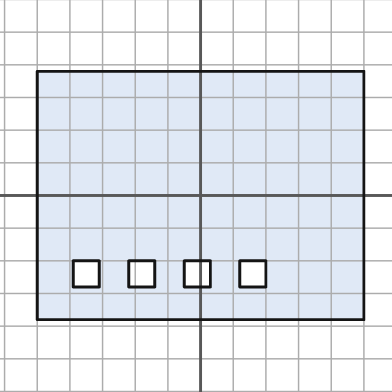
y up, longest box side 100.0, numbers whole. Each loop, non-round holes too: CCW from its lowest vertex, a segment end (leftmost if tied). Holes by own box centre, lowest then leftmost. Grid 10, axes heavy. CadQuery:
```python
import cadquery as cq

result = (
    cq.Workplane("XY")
    .moveTo(-50.0, -38.0)
    .lineTo(50.0, -38.0)
    .lineTo(50.0, 38.0)
    .lineTo(-50.0, 38.0)
    .close()
    .moveTo(-39.0, -28.0)
    .lineTo(-31.0, -28.0)
    .lineTo(-31.0, -20.0)
    .lineTo(-39.0, -20.0)
    .close()
    .moveTo(-22.0, -28.0)
    .lineTo(-14.0, -28.0)
    .lineTo(-14.0, -20.0)
    .lineTo(-22.0, -20.0)
    .close()
    .moveTo(-5.0, -28.0)
    .lineTo(3.0, -28.0)
    .lineTo(3.0, -20.0)
    .lineTo(-5.0, -20.0)
    .close()
    .moveTo(12.0, -28.0)
    .lineTo(20.0, -28.0)
    .lineTo(20.0, -20.0)
    .lineTo(12.0, -20.0)
    .close()
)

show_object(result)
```